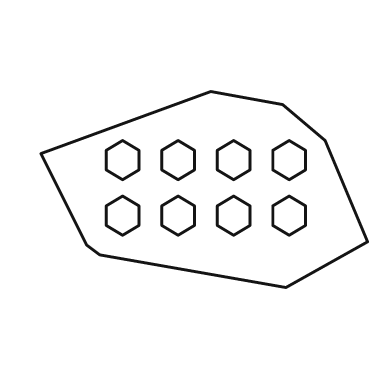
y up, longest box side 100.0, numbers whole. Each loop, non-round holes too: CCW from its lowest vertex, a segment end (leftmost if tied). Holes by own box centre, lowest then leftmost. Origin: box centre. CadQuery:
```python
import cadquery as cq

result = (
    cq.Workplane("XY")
    .moveTo(25.0, -30.0)
    .lineTo(50.0, -16.0)
    .lineTo(37.0, 15.0)
    .lineTo(24.0, 26.0)
    .lineTo(2.0, 30.0)
    .lineTo(-50.0, 11.0)
    .lineTo(-36.0, -17.0)
    .lineTo(-32.0, -20.0)
    .close()
    .moveTo(-25.0, -14.0)
    .lineTo(-20.0, -11.0)
    .lineTo(-20.0, -5.0)
    .lineTo(-25.0, -2.0)
    .lineTo(-30.0, -5.0)
    .lineTo(-30.0, -11.0)
    .close()
    .moveTo(-8.0, -14.0)
    .lineTo(-3.0, -11.0)
    .lineTo(-3.0, -5.0)
    .lineTo(-8.0, -2.0)
    .lineTo(-13.0, -5.0)
    .lineTo(-13.0, -11.0)
    .close()
    .moveTo(9.0, -14.0)
    .lineTo(14.0, -11.0)
    .lineTo(14.0, -5.0)
    .lineTo(9.0, -2.0)
    .lineTo(4.0, -5.0)
    .lineTo(4.0, -11.0)
    .close()
    .moveTo(26.0, -14.0)
    .lineTo(31.0, -11.0)
    .lineTo(31.0, -5.0)
    .lineTo(26.0, -2.0)
    .lineTo(21.0, -5.0)
    .lineTo(21.0, -11.0)
    .close()
    .moveTo(-25.0, 3.0)
    .lineTo(-20.0, 6.0)
    .lineTo(-20.0, 12.0)
    .lineTo(-25.0, 15.0)
    .lineTo(-30.0, 12.0)
    .lineTo(-30.0, 6.0)
    .close()
    .moveTo(-8.0, 3.0)
    .lineTo(-3.0, 6.0)
    .lineTo(-3.0, 12.0)
    .lineTo(-8.0, 15.0)
    .lineTo(-13.0, 12.0)
    .lineTo(-13.0, 6.0)
    .close()
    .moveTo(9.0, 3.0)
    .lineTo(14.0, 6.0)
    .lineTo(14.0, 12.0)
    .lineTo(9.0, 15.0)
    .lineTo(4.0, 12.0)
    .lineTo(4.0, 6.0)
    .close()
    .moveTo(26.0, 3.0)
    .lineTo(31.0, 6.0)
    .lineTo(31.0, 12.0)
    .lineTo(26.0, 15.0)
    .lineTo(21.0, 12.0)
    .lineTo(21.0, 6.0)
    .close()
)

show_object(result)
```